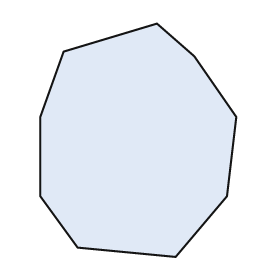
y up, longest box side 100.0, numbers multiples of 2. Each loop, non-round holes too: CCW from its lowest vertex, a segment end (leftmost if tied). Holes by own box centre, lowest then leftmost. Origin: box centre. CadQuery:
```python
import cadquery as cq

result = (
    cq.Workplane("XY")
    .moveTo(16.0, -50.0)
    .lineTo(38.0, -24.0)
    .lineTo(42.0, 10.0)
    .lineTo(24.0, 36.0)
    .lineTo(8.0, 50.0)
    .lineTo(-32.0, 38.0)
    .lineTo(-42.0, 10.0)
    .lineTo(-42.0, -24.0)
    .lineTo(-26.0, -46.0)
    .close()
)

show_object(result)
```